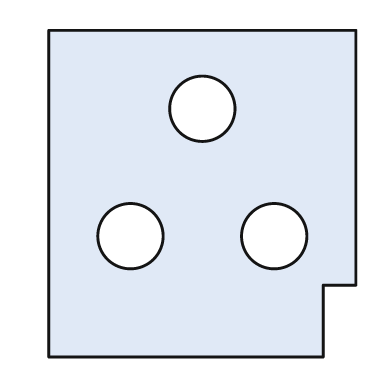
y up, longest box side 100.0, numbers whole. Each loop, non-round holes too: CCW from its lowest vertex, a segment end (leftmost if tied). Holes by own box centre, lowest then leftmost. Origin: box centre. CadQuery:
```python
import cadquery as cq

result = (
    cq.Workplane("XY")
    .moveTo(-47.0, -50.0)
    .lineTo(37.0, -50.0)
    .lineTo(37.0, -28.0)
    .lineTo(47.0, -28.0)
    .lineTo(47.0, 50.0)
    .lineTo(-47.0, 50.0)
    .close()
    .moveTo(-22.0, -13.0)
    .circle(10.0)
    .moveTo(22.0, -13.0)
    .circle(10.0)
    .moveTo(0.0, 26.0)
    .circle(10.0)
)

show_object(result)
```